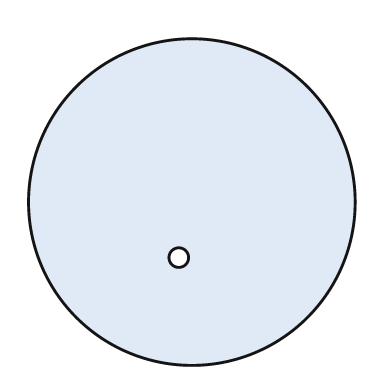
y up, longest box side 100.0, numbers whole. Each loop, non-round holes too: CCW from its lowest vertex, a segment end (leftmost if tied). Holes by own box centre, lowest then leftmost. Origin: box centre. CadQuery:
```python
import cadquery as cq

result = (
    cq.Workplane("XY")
    .moveTo(0.0, 0.0)
    .circle(50.0)
    .moveTo(-4.0, -17.0)
    .circle(3.0)
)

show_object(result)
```